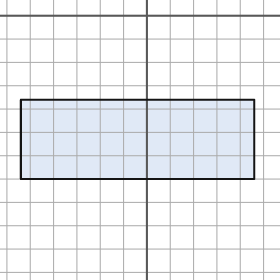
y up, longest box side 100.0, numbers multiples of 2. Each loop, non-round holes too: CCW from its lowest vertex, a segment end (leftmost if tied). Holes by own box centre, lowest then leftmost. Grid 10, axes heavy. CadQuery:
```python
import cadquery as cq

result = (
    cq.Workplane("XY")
    .moveTo(-54.0, -70.0)
    .lineTo(46.0, -70.0)
    .lineTo(46.0, -36.0)
    .lineTo(-54.0, -36.0)
    .close()
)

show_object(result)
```